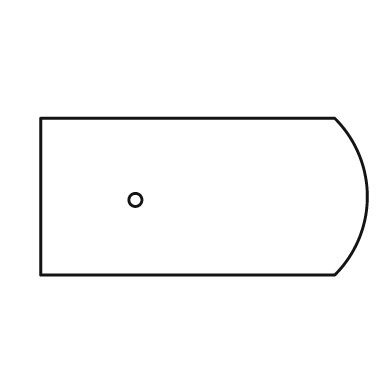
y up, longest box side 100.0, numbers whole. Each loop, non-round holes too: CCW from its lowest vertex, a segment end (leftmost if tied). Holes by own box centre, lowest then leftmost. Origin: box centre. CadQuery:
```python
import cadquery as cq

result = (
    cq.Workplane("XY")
    .moveTo(-50.0, -24.0)
    .lineTo(40.0, -24.0)
    .threePointArc((50.0, 0.0), (40.0, 24.0))
    .lineTo(-50.0, 24.0)
    .close()
    .moveTo(-21.0, -1.0)
    .circle(2.0)
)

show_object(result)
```